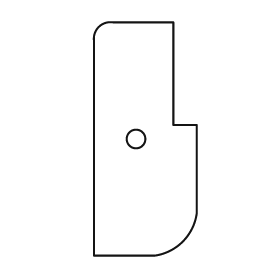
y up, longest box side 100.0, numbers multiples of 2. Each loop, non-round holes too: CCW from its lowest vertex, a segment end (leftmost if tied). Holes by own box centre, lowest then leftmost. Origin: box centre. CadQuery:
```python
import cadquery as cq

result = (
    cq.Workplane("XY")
    .moveTo(-22.0, -50.0)
    .lineTo(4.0, -50.0)
    .threePointArc((16.0, -44.0), (22.0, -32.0))
    .lineTo(22.0, 6.0)
    .lineTo(12.0, 6.0)
    .lineTo(12.0, 50.0)
    .lineTo(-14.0, 50.0)
    .threePointArc((-20.0, 48.0), (-22.0, 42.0))
    .close()
    .moveTo(-4.0, 0.0)
    .circle(4.0)
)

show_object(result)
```